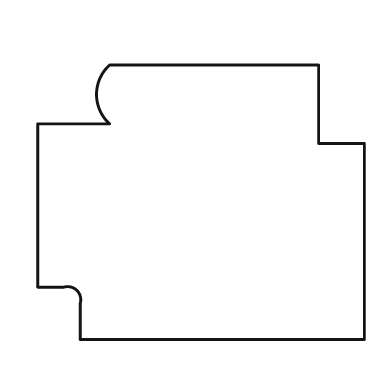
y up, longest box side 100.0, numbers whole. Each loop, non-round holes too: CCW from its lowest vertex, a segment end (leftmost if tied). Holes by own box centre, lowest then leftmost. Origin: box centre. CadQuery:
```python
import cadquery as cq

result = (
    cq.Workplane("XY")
    .moveTo(-37.0, -42.0)
    .lineTo(50.0, -42.0)
    .lineTo(50.0, 18.0)
    .lineTo(36.0, 18.0)
    .lineTo(36.0, 42.0)
    .lineTo(-28.0, 42.0)
    .threePointArc((-32.0, 33.0), (-28.0, 24.0))
    .lineTo(-50.0, 24.0)
    .lineTo(-50.0, -26.0)
    .lineTo(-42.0, -26.0)
    .threePointArc((-38.0, -27.0), (-37.0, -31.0))
    .close()
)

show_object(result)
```